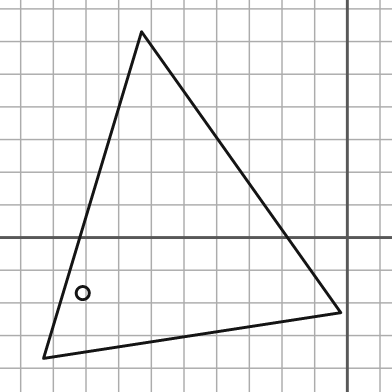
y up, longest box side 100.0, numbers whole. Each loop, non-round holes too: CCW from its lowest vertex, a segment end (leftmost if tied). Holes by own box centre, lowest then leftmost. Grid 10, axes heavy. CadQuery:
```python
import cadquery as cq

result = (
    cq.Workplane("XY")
    .moveTo(-93.0, -37.0)
    .lineTo(-2.0, -23.0)
    .lineTo(-63.0, 63.0)
    .close()
    .moveTo(-81.0, -17.0)
    .circle(2.0)
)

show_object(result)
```